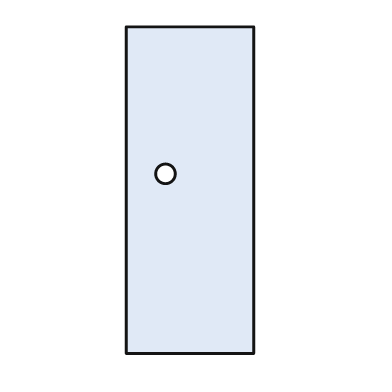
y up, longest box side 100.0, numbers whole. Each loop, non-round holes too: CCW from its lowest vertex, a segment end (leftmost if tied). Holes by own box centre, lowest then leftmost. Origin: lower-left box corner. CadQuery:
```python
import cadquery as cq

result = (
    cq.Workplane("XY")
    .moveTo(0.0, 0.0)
    .lineTo(39.0, 0.0)
    .lineTo(39.0, 100.0)
    .lineTo(0.0, 100.0)
    .close()
    .moveTo(12.0, 55.0)
    .circle(3.0)
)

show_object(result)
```